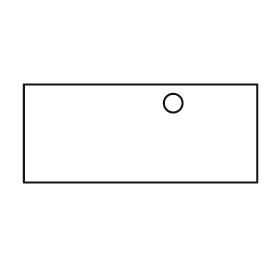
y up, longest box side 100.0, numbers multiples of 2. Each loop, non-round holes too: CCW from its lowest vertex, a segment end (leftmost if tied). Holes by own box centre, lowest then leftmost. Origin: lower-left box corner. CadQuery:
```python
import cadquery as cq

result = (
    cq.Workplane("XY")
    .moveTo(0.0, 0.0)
    .lineTo(100.0, 0.0)
    .lineTo(100.0, 42.0)
    .lineTo(0.0, 42.0)
    .close()
    .moveTo(64.0, 34.0)
    .circle(4.0)
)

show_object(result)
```